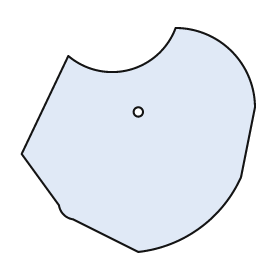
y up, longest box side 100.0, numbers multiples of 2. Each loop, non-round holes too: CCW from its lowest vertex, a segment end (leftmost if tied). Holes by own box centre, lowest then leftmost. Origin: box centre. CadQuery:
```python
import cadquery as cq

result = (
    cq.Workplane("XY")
    .moveTo(0.0, -48.0)
    .threePointArc((26.0, -38.0), (44.0, -16.0))
    .lineTo(50.0, 14.0)
    .threePointArc((40.0, 38.0), (16.0, 48.0))
    .threePointArc((-4.0, 30.0), (-30.0, 36.0))
    .lineTo(-50.0, -6.0)
    .lineTo(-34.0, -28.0)
    .threePointArc((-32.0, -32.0), (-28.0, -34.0))
    .close()
    .moveTo(0.0, 12.0)
    .circle(2.0)
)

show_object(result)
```